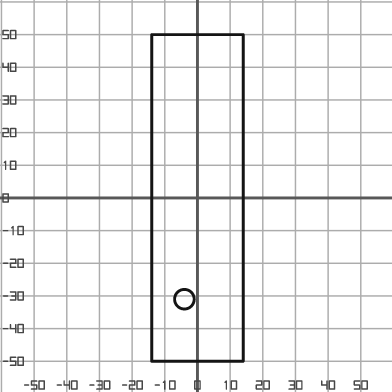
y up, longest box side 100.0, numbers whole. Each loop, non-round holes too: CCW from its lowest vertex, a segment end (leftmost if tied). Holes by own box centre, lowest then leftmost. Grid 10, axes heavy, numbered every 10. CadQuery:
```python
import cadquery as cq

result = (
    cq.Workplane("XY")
    .moveTo(-14.0, -50.0)
    .lineTo(14.0, -50.0)
    .lineTo(14.0, 50.0)
    .lineTo(-14.0, 50.0)
    .close()
    .moveTo(-4.0, -31.0)
    .circle(3.0)
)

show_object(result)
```